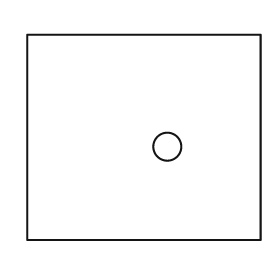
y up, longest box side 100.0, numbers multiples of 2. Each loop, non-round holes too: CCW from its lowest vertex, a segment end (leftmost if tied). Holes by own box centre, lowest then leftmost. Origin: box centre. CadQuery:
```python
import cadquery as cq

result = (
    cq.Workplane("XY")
    .moveTo(-50.0, -44.0)
    .lineTo(50.0, -44.0)
    .lineTo(50.0, 44.0)
    .lineTo(-50.0, 44.0)
    .close()
    .moveTo(10.0, -4.0)
    .circle(6.0)
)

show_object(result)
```